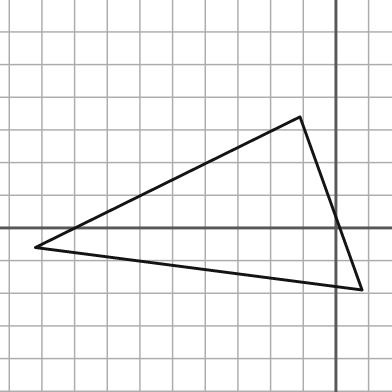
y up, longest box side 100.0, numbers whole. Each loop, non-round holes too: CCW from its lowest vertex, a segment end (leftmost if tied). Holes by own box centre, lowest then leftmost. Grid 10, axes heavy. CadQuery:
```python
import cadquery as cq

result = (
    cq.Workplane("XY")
    .moveTo(8.0, -19.0)
    .lineTo(-11.0, 34.0)
    .lineTo(-92.0, -6.0)
    .close()
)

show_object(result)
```